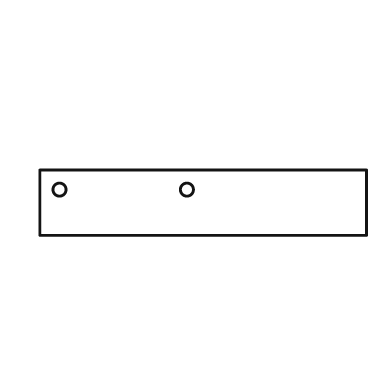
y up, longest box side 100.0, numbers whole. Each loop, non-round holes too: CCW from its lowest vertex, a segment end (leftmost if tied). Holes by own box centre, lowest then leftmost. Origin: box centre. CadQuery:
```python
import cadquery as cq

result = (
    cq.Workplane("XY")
    .moveTo(-50.0, -10.0)
    .lineTo(50.0, -10.0)
    .lineTo(50.0, 10.0)
    .lineTo(-50.0, 10.0)
    .close()
    .moveTo(-44.0, 4.0)
    .circle(2.0)
    .moveTo(-5.0, 4.0)
    .circle(2.0)
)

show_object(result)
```